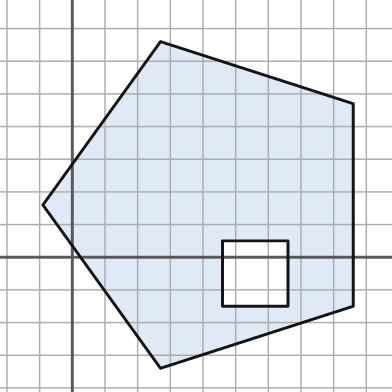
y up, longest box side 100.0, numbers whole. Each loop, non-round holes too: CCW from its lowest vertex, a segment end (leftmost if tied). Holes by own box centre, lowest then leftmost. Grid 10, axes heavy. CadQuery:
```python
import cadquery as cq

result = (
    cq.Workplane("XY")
    .moveTo(27.0, -34.0)
    .lineTo(86.0, -15.0)
    .lineTo(86.0, 47.0)
    .lineTo(27.0, 66.0)
    .lineTo(-9.0, 16.0)
    .close()
    .moveTo(46.0, -15.0)
    .lineTo(66.0, -15.0)
    .lineTo(66.0, 5.0)
    .lineTo(46.0, 5.0)
    .close()
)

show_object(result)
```